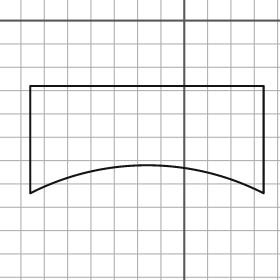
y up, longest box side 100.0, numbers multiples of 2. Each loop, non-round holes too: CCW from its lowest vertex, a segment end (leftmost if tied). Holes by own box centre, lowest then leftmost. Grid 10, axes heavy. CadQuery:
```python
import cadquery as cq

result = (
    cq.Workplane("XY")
    .moveTo(-66.0, -74.0)
    .threePointArc((-16.0, -62.0), (34.0, -74.0))
    .lineTo(34.0, -28.0)
    .lineTo(-66.0, -28.0)
    .close()
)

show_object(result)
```